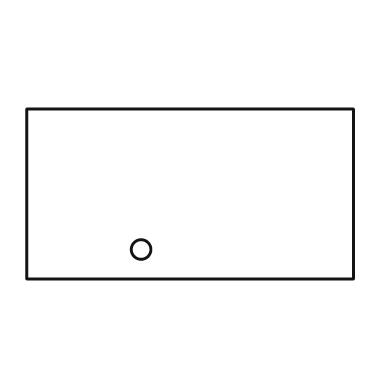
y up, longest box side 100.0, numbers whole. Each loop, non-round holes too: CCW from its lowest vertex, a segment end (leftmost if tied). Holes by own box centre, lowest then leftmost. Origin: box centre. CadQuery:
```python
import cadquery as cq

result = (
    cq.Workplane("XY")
    .moveTo(-50.0, -26.0)
    .lineTo(50.0, -26.0)
    .lineTo(50.0, 26.0)
    .lineTo(-50.0, 26.0)
    .close()
    .moveTo(-15.0, -17.0)
    .circle(3.0)
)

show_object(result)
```